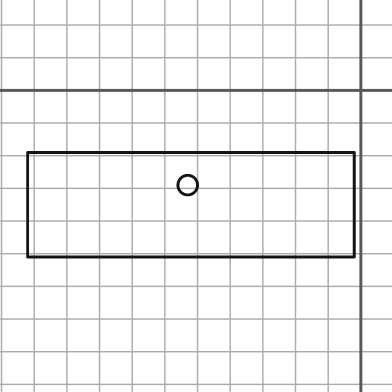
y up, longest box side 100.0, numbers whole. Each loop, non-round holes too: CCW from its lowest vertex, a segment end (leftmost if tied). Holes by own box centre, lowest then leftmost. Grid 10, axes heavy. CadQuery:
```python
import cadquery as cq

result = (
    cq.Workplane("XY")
    .moveTo(-102.0, -51.0)
    .lineTo(-2.0, -51.0)
    .lineTo(-2.0, -19.0)
    .lineTo(-102.0, -19.0)
    .close()
    .moveTo(-53.0, -29.0)
    .circle(3.0)
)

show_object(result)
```